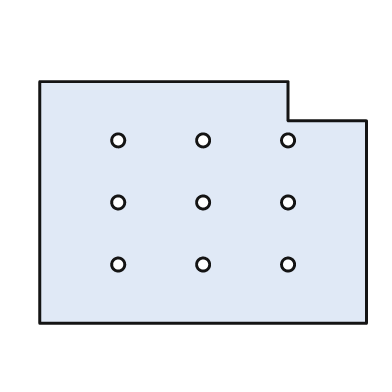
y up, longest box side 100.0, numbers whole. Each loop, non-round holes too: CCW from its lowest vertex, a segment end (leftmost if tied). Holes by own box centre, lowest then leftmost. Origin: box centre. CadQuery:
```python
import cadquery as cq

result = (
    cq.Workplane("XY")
    .moveTo(-50.0, -37.0)
    .lineTo(50.0, -37.0)
    .lineTo(50.0, 25.0)
    .lineTo(26.0, 25.0)
    .lineTo(26.0, 37.0)
    .lineTo(-50.0, 37.0)
    .close()
    .moveTo(-26.0, -19.0)
    .circle(2.0)
    .moveTo(0.0, -19.0)
    .circle(2.0)
    .moveTo(26.0, -19.0)
    .circle(2.0)
    .moveTo(-26.0, 0.0)
    .circle(2.0)
    .moveTo(0.0, 0.0)
    .circle(2.0)
    .moveTo(26.0, 0.0)
    .circle(2.0)
    .moveTo(-26.0, 19.0)
    .circle(2.0)
    .moveTo(0.0, 19.0)
    .circle(2.0)
    .moveTo(26.0, 19.0)
    .circle(2.0)
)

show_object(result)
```